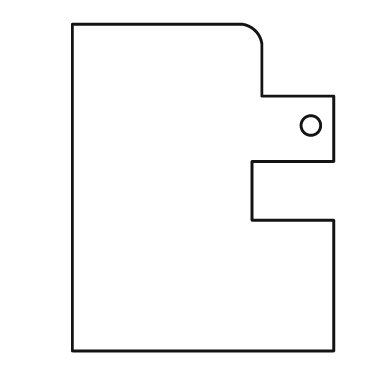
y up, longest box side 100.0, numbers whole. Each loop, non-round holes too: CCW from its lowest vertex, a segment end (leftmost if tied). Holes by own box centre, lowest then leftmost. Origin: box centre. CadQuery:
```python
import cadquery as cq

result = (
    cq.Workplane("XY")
    .moveTo(-40.0, -50.0)
    .lineTo(40.0, -50.0)
    .lineTo(40.0, -10.0)
    .lineTo(15.0, -10.0)
    .lineTo(15.0, 8.0)
    .lineTo(40.0, 8.0)
    .lineTo(40.0, 28.0)
    .lineTo(18.0, 28.0)
    .lineTo(18.0, 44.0)
    .threePointArc((16.0, 48.0), (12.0, 50.0))
    .lineTo(-40.0, 50.0)
    .close()
    .moveTo(33.0, 19.0)
    .circle(3.0)
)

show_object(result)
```